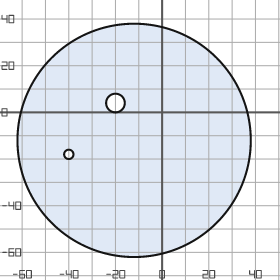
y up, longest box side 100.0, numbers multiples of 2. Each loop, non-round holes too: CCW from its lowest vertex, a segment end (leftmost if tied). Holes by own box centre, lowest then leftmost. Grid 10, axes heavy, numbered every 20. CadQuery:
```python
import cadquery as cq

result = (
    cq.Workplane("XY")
    .moveTo(-12.0, -12.0)
    .circle(50.0)
    .moveTo(-40.0, -18.0)
    .circle(2.0)
    .moveTo(-20.0, 4.0)
    .circle(4.0)
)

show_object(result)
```